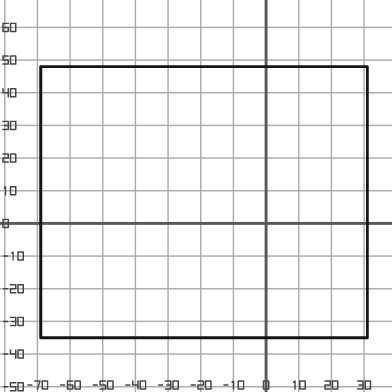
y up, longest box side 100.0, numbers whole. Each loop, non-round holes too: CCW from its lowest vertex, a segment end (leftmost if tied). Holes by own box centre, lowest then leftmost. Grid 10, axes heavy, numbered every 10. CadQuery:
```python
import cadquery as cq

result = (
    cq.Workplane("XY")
    .moveTo(-69.0, -35.0)
    .lineTo(31.0, -35.0)
    .lineTo(31.0, 48.0)
    .lineTo(-69.0, 48.0)
    .close()
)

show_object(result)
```